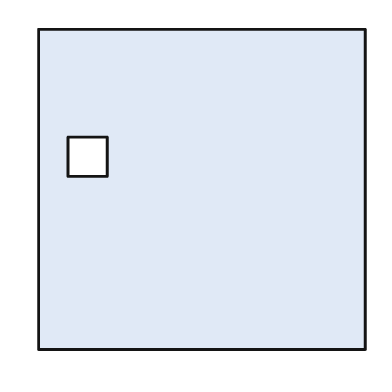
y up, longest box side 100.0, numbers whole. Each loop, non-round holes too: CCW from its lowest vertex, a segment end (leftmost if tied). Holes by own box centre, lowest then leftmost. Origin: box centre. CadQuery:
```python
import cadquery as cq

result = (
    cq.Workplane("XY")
    .moveTo(-50.0, -49.0)
    .lineTo(50.0, -49.0)
    .lineTo(50.0, 49.0)
    .lineTo(-50.0, 49.0)
    .close()
    .moveTo(-41.0, 4.0)
    .lineTo(-29.0, 4.0)
    .lineTo(-29.0, 16.0)
    .lineTo(-41.0, 16.0)
    .close()
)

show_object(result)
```